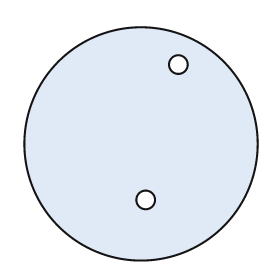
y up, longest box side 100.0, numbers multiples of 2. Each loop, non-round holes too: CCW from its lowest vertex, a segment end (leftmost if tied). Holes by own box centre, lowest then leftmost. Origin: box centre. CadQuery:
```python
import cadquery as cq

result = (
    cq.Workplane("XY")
    .moveTo(0.0, 0.0)
    .circle(50.0)
    .moveTo(2.0, -24.0)
    .circle(4.0)
    .moveTo(16.0, 34.0)
    .circle(4.0)
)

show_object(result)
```